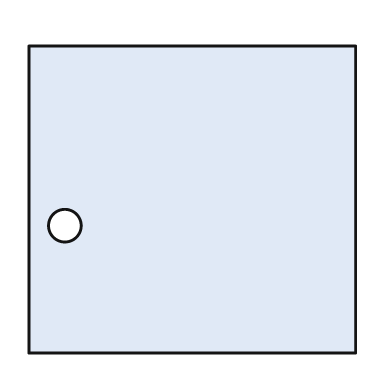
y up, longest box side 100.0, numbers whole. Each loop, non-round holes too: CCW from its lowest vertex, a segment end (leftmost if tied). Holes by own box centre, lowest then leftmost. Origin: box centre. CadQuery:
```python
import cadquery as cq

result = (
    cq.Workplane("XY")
    .moveTo(-50.0, -47.0)
    .lineTo(50.0, -47.0)
    .lineTo(50.0, 47.0)
    .lineTo(-50.0, 47.0)
    .close()
    .moveTo(-39.0, -8.0)
    .circle(5.0)
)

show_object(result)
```